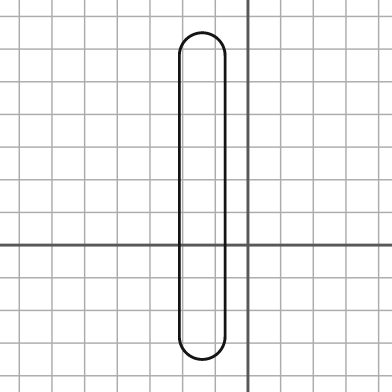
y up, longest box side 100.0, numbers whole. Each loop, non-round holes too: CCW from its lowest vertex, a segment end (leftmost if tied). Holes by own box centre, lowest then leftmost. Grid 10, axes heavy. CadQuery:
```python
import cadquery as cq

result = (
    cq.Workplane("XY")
    .moveTo(-21.0, -28.0)
    .threePointArc((-14.0, -35.0), (-7.0, -28.0))
    .lineTo(-7.0, 58.0)
    .threePointArc((-14.0, 65.0), (-21.0, 58.0))
    .close()
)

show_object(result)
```